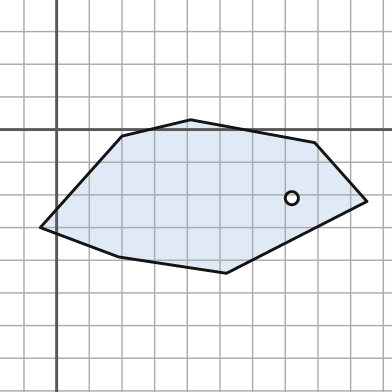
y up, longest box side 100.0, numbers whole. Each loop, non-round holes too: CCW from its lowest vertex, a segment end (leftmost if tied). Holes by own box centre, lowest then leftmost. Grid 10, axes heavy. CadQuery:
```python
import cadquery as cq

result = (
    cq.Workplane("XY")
    .moveTo(52.0, -44.0)
    .lineTo(95.0, -22.0)
    .lineTo(79.0, -4.0)
    .lineTo(41.0, 3.0)
    .lineTo(20.0, -2.0)
    .lineTo(-5.0, -30.0)
    .lineTo(19.0, -39.0)
    .close()
    .moveTo(72.0, -21.0)
    .circle(2.0)
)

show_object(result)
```